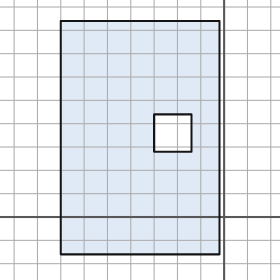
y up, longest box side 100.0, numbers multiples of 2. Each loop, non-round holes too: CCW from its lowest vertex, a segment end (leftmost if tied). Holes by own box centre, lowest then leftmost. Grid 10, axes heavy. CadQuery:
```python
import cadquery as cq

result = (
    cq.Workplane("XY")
    .moveTo(-70.0, -16.0)
    .lineTo(-2.0, -16.0)
    .lineTo(-2.0, 84.0)
    .lineTo(-70.0, 84.0)
    .close()
    .moveTo(-30.0, 28.0)
    .lineTo(-14.0, 28.0)
    .lineTo(-14.0, 44.0)
    .lineTo(-30.0, 44.0)
    .close()
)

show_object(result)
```